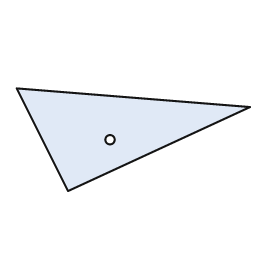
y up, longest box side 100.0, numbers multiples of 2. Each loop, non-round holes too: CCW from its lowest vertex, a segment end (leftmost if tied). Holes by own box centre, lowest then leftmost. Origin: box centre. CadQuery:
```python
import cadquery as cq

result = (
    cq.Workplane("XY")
    .moveTo(-28.0, -22.0)
    .lineTo(50.0, 14.0)
    .lineTo(-50.0, 22.0)
    .close()
    .moveTo(-10.0, 0.0)
    .circle(2.0)
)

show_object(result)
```